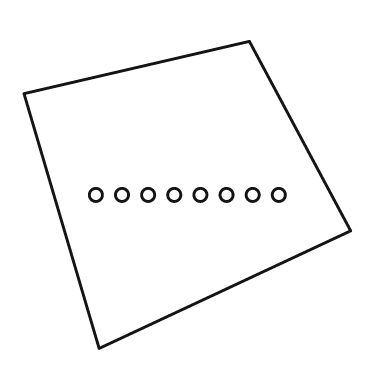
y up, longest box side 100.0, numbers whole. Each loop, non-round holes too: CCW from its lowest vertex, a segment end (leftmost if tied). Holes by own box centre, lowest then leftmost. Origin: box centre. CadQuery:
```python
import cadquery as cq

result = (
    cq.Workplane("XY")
    .moveTo(-27.0, -47.0)
    .lineTo(50.0, -11.0)
    .lineTo(19.0, 47.0)
    .lineTo(-50.0, 31.0)
    .close()
    .moveTo(-28.0, 0.0)
    .circle(2.0)
    .moveTo(-20.0, 0.0)
    .circle(2.0)
    .moveTo(-12.0, 0.0)
    .circle(2.0)
    .moveTo(-4.0, 0.0)
    .circle(2.0)
    .moveTo(4.0, 0.0)
    .circle(2.0)
    .moveTo(12.0, 0.0)
    .circle(2.0)
    .moveTo(20.0, 0.0)
    .circle(2.0)
    .moveTo(28.0, 0.0)
    .circle(2.0)
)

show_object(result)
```